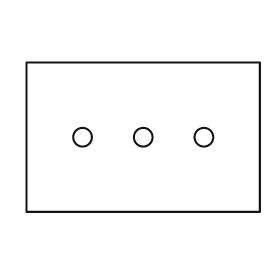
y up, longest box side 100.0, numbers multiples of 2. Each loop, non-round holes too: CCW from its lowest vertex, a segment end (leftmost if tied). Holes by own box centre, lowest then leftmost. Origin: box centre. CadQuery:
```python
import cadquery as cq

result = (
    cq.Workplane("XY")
    .moveTo(-50.0, -32.0)
    .lineTo(50.0, -32.0)
    .lineTo(50.0, 32.0)
    .lineTo(-50.0, 32.0)
    .close()
    .moveTo(-26.0, 0.0)
    .circle(4.0)
    .moveTo(0.0, 0.0)
    .circle(4.0)
    .moveTo(26.0, 0.0)
    .circle(4.0)
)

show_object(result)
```